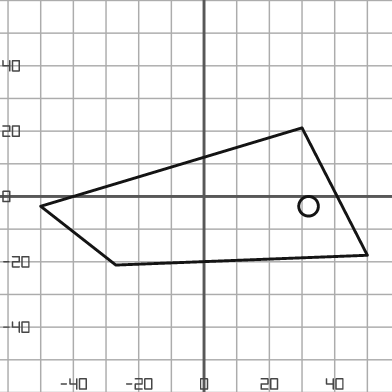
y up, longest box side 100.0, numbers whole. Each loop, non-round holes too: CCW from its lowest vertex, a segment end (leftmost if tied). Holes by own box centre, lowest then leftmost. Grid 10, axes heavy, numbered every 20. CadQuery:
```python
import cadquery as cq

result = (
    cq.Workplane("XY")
    .moveTo(-27.0, -21.0)
    .lineTo(50.0, -18.0)
    .lineTo(30.0, 21.0)
    .lineTo(-50.0, -3.0)
    .close()
    .moveTo(32.0, -3.0)
    .circle(3.0)
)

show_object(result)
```